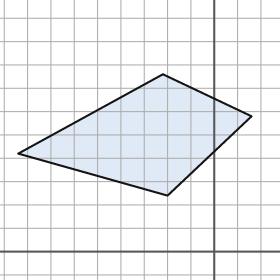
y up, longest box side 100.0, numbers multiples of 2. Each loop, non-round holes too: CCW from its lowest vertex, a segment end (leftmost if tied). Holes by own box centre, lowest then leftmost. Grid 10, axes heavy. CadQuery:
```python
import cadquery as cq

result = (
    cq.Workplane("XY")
    .moveTo(-20.0, 24.0)
    .lineTo(16.0, 58.0)
    .lineTo(-22.0, 76.0)
    .lineTo(-84.0, 42.0)
    .close()
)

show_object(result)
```